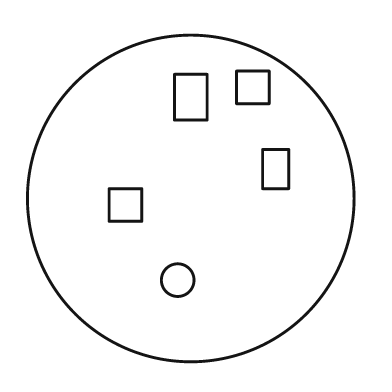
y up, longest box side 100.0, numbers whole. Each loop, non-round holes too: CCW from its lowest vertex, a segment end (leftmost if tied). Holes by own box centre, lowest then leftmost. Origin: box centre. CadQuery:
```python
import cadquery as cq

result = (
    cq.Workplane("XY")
    .moveTo(0.0, 0.0)
    .circle(50.0)
    .moveTo(-4.0, -25.0)
    .circle(5.0)
    .moveTo(-25.0, -7.0)
    .lineTo(-15.0, -7.0)
    .lineTo(-15.0, 3.0)
    .lineTo(-25.0, 3.0)
    .close()
    .moveTo(22.0, 3.0)
    .lineTo(30.0, 3.0)
    .lineTo(30.0, 15.0)
    .lineTo(22.0, 15.0)
    .close()
    .moveTo(-5.0, 24.0)
    .lineTo(5.0, 24.0)
    .lineTo(5.0, 38.0)
    .lineTo(-5.0, 38.0)
    .close()
    .moveTo(14.0, 29.0)
    .lineTo(24.0, 29.0)
    .lineTo(24.0, 39.0)
    .lineTo(14.0, 39.0)
    .close()
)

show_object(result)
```